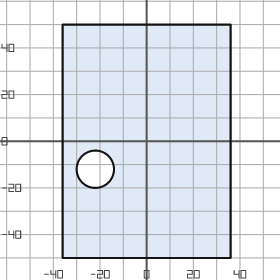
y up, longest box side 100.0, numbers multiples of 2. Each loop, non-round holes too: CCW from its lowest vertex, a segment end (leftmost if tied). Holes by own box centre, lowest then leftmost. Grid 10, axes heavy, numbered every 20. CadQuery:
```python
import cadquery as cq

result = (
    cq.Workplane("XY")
    .moveTo(-36.0, -50.0)
    .lineTo(36.0, -50.0)
    .lineTo(36.0, 50.0)
    .lineTo(-36.0, 50.0)
    .close()
    .moveTo(-22.0, -12.0)
    .circle(8.0)
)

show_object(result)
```